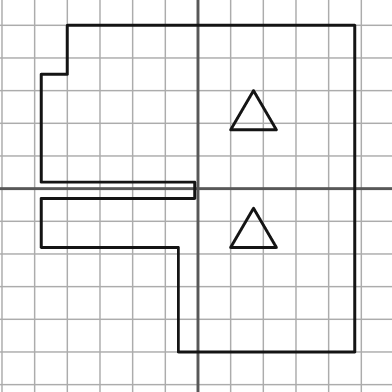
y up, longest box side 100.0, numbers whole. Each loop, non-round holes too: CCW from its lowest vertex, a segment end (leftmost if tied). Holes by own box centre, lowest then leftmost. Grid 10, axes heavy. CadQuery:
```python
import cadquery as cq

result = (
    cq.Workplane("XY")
    .moveTo(-6.0, -50.0)
    .lineTo(48.0, -50.0)
    .lineTo(48.0, 50.0)
    .lineTo(-40.0, 50.0)
    .lineTo(-40.0, 35.0)
    .lineTo(-48.0, 35.0)
    .lineTo(-48.0, 2.0)
    .lineTo(-1.0, 2.0)
    .lineTo(-1.0, -3.0)
    .lineTo(-48.0, -3.0)
    .lineTo(-48.0, -18.0)
    .lineTo(-6.0, -18.0)
    .close()
    .moveTo(10.0, -18.0)
    .lineTo(24.0, -18.0)
    .lineTo(17.0, -6.0)
    .close()
    .moveTo(10.0, 18.0)
    .lineTo(24.0, 18.0)
    .lineTo(17.0, 30.0)
    .close()
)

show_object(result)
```